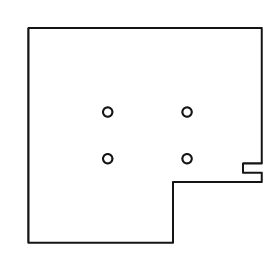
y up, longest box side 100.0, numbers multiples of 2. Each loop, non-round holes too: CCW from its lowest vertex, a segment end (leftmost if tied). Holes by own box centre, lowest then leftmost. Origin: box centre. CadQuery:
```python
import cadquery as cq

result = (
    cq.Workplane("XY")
    .moveTo(-50.0, -46.0)
    .lineTo(12.0, -46.0)
    .lineTo(12.0, -20.0)
    .lineTo(50.0, -20.0)
    .lineTo(50.0, -16.0)
    .lineTo(42.0, -16.0)
    .lineTo(42.0, -12.0)
    .lineTo(50.0, -12.0)
    .lineTo(50.0, 46.0)
    .lineTo(-50.0, 46.0)
    .close()
    .moveTo(-16.0, -10.0)
    .circle(2.0)
    .moveTo(18.0, -10.0)
    .circle(2.0)
    .moveTo(-16.0, 10.0)
    .circle(2.0)
    .moveTo(18.0, 10.0)
    .circle(2.0)
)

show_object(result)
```